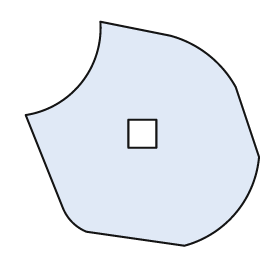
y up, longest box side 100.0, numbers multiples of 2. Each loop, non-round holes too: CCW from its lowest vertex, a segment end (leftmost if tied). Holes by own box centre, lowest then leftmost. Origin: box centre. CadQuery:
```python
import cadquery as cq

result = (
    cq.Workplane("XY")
    .moveTo(18.0, -48.0)
    .threePointArc((40.0, -34.0), (50.0, -10.0))
    .lineTo(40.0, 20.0)
    .threePointArc((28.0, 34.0), (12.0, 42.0))
    .lineTo(-18.0, 48.0)
    .threePointArc((-26.0, 22.0), (-50.0, 8.0))
    .lineTo(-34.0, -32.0)
    .threePointArc((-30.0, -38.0), (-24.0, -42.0))
    .close()
    .moveTo(-6.0, -6.0)
    .lineTo(6.0, -6.0)
    .lineTo(6.0, 6.0)
    .lineTo(-6.0, 6.0)
    .close()
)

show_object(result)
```